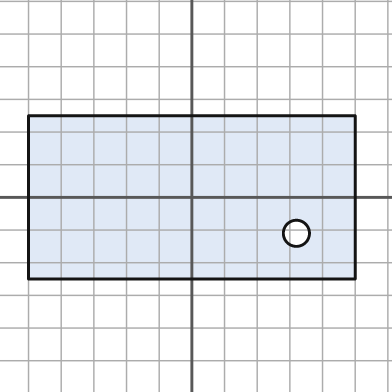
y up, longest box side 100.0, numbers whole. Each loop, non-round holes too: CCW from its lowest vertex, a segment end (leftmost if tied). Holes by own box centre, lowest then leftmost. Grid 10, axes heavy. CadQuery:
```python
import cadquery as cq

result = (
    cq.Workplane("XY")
    .moveTo(-50.0, -25.0)
    .lineTo(50.0, -25.0)
    .lineTo(50.0, 25.0)
    .lineTo(-50.0, 25.0)
    .close()
    .moveTo(32.0, -11.0)
    .circle(4.0)
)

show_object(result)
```